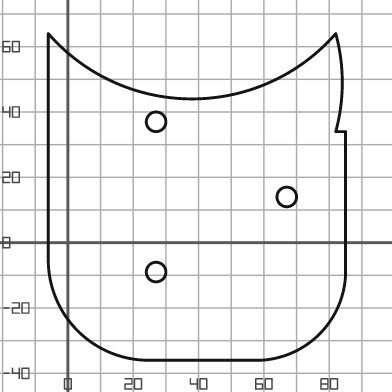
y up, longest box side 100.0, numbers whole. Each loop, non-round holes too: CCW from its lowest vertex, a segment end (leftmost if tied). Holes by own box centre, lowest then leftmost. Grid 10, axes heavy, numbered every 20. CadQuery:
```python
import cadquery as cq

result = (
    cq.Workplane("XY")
    .moveTo(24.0, -36.0)
    .lineTo(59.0, -36.0)
    .threePointArc((77.0, -28.0), (85.0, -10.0))
    .lineTo(85.0, 34.0)
    .lineTo(82.0, 34.0)
    .threePointArc((84.0, 49.0), (82.0, 64.0))
    .threePointArc((38.0, 44.0), (-6.0, 64.0))
    .lineTo(-6.0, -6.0)
    .threePointArc((3.0, -27.0), (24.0, -36.0))
    .close()
    .moveTo(27.0, -9.0)
    .circle(3.0)
    .moveTo(67.0, 14.0)
    .circle(3.0)
    .moveTo(27.0, 37.0)
    .circle(3.0)
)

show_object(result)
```